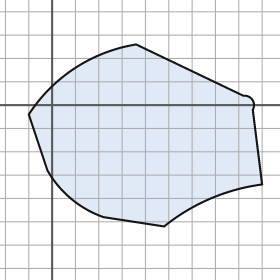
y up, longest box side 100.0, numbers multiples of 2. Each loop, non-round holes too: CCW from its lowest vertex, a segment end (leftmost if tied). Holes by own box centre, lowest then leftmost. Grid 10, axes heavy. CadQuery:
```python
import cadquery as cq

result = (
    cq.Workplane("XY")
    .moveTo(48.0, -52.0)
    .threePointArc((68.0, -40.0), (90.0, -34.0))
    .lineTo(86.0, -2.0)
    .threePointArc((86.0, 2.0), (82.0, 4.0))
    .lineTo(36.0, 26.0)
    .threePointArc((10.0, 16.0), (-10.0, -4.0))
    .lineTo(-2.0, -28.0)
    .threePointArc((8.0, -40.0), (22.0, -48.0))
    .close()
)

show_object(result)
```